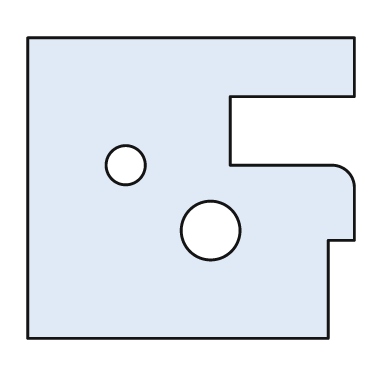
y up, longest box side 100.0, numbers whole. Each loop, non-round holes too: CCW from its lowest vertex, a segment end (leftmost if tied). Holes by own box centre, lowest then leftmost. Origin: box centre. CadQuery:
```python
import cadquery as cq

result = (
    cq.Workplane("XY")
    .moveTo(-50.0, -46.0)
    .lineTo(42.0, -46.0)
    .lineTo(42.0, -16.0)
    .lineTo(50.0, -16.0)
    .lineTo(50.0, 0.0)
    .threePointArc((48.0, 5.0), (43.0, 7.0))
    .lineTo(12.0, 7.0)
    .lineTo(12.0, 28.0)
    .lineTo(50.0, 28.0)
    .lineTo(50.0, 46.0)
    .lineTo(-50.0, 46.0)
    .close()
    .moveTo(6.0, -13.0)
    .circle(9.0)
    .moveTo(-20.0, 7.0)
    .circle(6.0)
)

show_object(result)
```